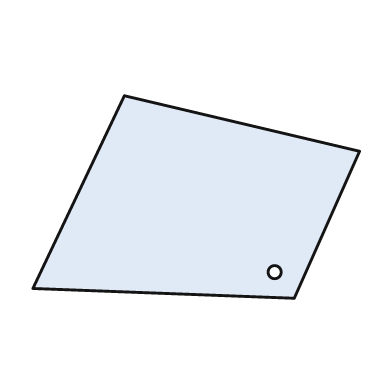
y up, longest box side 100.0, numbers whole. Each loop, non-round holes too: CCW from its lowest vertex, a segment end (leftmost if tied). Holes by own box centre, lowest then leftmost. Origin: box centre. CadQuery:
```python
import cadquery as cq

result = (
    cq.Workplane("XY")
    .moveTo(30.0, -31.0)
    .lineTo(50.0, 14.0)
    .lineTo(-22.0, 31.0)
    .lineTo(-50.0, -28.0)
    .close()
    .moveTo(24.0, -23.0)
    .circle(2.0)
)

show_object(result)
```